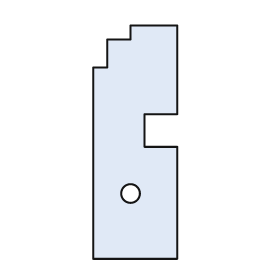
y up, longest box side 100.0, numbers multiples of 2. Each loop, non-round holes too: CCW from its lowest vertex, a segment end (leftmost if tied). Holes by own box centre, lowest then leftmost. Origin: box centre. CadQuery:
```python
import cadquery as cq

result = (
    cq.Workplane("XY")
    .moveTo(-18.0, -50.0)
    .lineTo(18.0, -50.0)
    .lineTo(18.0, -2.0)
    .lineTo(4.0, -2.0)
    .lineTo(4.0, 12.0)
    .lineTo(18.0, 12.0)
    .lineTo(18.0, 50.0)
    .lineTo(-2.0, 50.0)
    .lineTo(-2.0, 44.0)
    .lineTo(-12.0, 44.0)
    .lineTo(-12.0, 32.0)
    .lineTo(-18.0, 32.0)
    .close()
    .moveTo(-2.0, -22.0)
    .circle(4.0)
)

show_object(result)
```